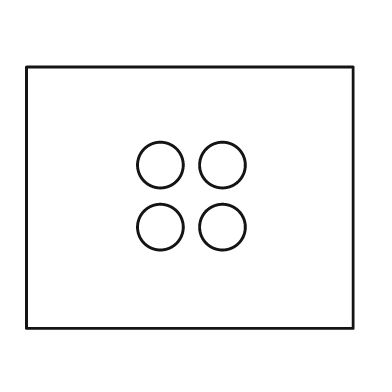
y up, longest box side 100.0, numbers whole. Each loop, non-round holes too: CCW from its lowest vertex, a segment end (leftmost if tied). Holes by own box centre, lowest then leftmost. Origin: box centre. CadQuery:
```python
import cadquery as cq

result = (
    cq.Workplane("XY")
    .moveTo(-50.0, -40.0)
    .lineTo(50.0, -40.0)
    .lineTo(50.0, 40.0)
    .lineTo(-50.0, 40.0)
    .close()
    .moveTo(-9.0, -9.0)
    .circle(7.0)
    .moveTo(10.0, -9.0)
    .circle(7.0)
    .moveTo(-9.0, 10.0)
    .circle(7.0)
    .moveTo(10.0, 10.0)
    .circle(7.0)
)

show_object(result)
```